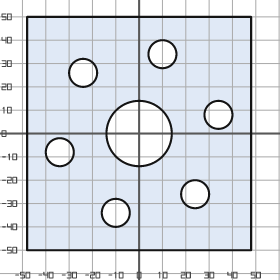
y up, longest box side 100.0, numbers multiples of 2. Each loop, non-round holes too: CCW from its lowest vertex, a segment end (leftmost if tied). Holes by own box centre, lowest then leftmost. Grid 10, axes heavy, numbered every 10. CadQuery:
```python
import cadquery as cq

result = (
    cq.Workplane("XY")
    .moveTo(-48.0, -50.0)
    .lineTo(48.0, -50.0)
    .lineTo(48.0, 50.0)
    .lineTo(-48.0, 50.0)
    .close()
    .moveTo(-10.0, -34.0)
    .circle(6.0)
    .moveTo(24.0, -26.0)
    .circle(6.0)
    .moveTo(-34.0, -8.0)
    .circle(6.0)
    .moveTo(0.0, 0.0)
    .circle(14.0)
    .moveTo(34.0, 8.0)
    .circle(6.0)
    .moveTo(-24.0, 26.0)
    .circle(6.0)
    .moveTo(10.0, 34.0)
    .circle(6.0)
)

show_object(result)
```